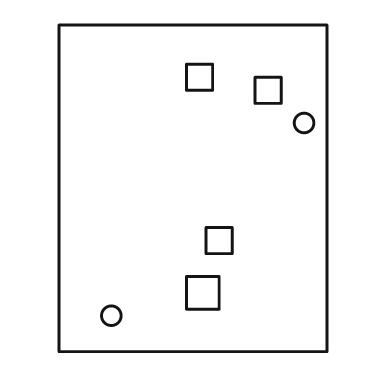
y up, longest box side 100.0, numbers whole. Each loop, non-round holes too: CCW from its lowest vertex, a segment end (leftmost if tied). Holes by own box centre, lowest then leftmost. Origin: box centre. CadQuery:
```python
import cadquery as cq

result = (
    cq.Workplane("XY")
    .moveTo(-41.0, -50.0)
    .lineTo(41.0, -50.0)
    .lineTo(41.0, 50.0)
    .lineTo(-41.0, 50.0)
    .close()
    .moveTo(-25.0, -39.0)
    .circle(3.0)
    .moveTo(-2.0, -37.0)
    .lineTo(8.0, -37.0)
    .lineTo(8.0, -27.0)
    .lineTo(-2.0, -27.0)
    .close()
    .moveTo(4.0, -20.0)
    .lineTo(12.0, -20.0)
    .lineTo(12.0, -12.0)
    .lineTo(4.0, -12.0)
    .close()
    .moveTo(34.0, 20.0)
    .circle(3.0)
    .moveTo(19.0, 26.0)
    .lineTo(27.0, 26.0)
    .lineTo(27.0, 34.0)
    .lineTo(19.0, 34.0)
    .close()
    .moveTo(-2.0, 30.0)
    .lineTo(6.0, 30.0)
    .lineTo(6.0, 38.0)
    .lineTo(-2.0, 38.0)
    .close()
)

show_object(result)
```